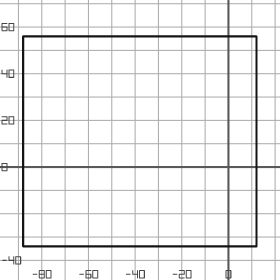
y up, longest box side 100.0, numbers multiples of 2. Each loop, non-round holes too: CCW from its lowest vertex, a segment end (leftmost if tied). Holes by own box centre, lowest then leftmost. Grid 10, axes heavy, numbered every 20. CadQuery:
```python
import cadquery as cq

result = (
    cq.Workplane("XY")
    .moveTo(-88.0, -34.0)
    .lineTo(12.0, -34.0)
    .lineTo(12.0, 56.0)
    .lineTo(-88.0, 56.0)
    .close()
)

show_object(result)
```